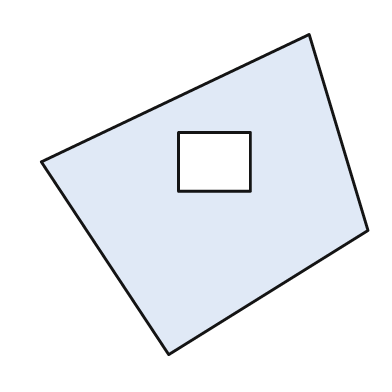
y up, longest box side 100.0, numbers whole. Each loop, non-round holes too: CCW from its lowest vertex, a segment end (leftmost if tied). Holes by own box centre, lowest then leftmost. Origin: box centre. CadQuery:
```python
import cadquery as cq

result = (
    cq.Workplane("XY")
    .moveTo(-11.0, -49.0)
    .lineTo(50.0, -11.0)
    .lineTo(32.0, 49.0)
    .lineTo(-50.0, 10.0)
    .close()
    .moveTo(-8.0, 1.0)
    .lineTo(14.0, 1.0)
    .lineTo(14.0, 19.0)
    .lineTo(-8.0, 19.0)
    .close()
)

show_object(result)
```